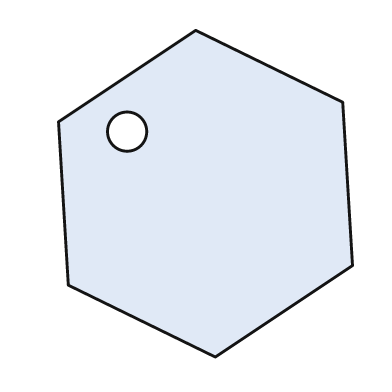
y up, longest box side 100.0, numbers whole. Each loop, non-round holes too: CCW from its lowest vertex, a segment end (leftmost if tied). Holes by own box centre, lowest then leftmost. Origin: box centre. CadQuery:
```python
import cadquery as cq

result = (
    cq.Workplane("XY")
    .moveTo(3.0, -50.0)
    .lineTo(45.0, -22.0)
    .lineTo(42.0, 28.0)
    .lineTo(-3.0, 50.0)
    .lineTo(-45.0, 22.0)
    .lineTo(-42.0, -28.0)
    .close()
    .moveTo(-24.0, 19.0)
    .circle(6.0)
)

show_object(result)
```